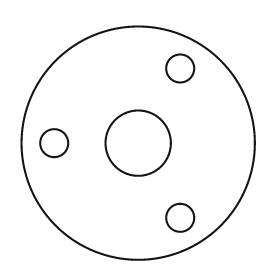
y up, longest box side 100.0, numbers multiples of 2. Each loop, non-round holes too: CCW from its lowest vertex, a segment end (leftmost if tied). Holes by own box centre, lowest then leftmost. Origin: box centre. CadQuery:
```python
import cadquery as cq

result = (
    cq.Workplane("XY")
    .moveTo(0.0, 0.0)
    .circle(50.0)
    .moveTo(18.0, -32.0)
    .circle(6.0)
    .moveTo(-36.0, 0.0)
    .circle(6.0)
    .moveTo(0.0, 0.0)
    .circle(14.0)
    .moveTo(18.0, 32.0)
    .circle(6.0)
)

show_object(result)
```